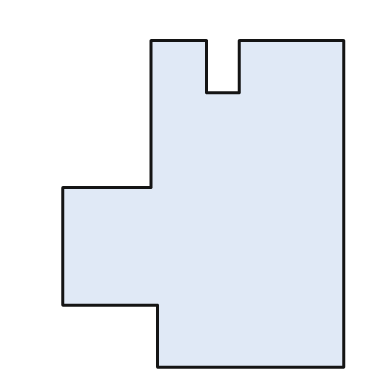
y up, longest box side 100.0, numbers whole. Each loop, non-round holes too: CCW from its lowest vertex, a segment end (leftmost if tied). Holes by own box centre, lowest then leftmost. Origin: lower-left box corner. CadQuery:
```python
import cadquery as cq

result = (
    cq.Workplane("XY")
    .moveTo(29.0, 0.0)
    .lineTo(86.0, 0.0)
    .lineTo(86.0, 100.0)
    .lineTo(54.0, 100.0)
    .lineTo(54.0, 84.0)
    .lineTo(44.0, 84.0)
    .lineTo(44.0, 100.0)
    .lineTo(27.0, 100.0)
    .lineTo(27.0, 55.0)
    .lineTo(0.0, 55.0)
    .lineTo(0.0, 19.0)
    .lineTo(29.0, 19.0)
    .close()
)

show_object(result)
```